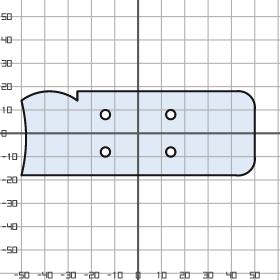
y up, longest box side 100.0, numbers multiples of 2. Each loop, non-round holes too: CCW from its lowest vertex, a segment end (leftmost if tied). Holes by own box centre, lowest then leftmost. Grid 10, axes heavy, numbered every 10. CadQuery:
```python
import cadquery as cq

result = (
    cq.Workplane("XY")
    .moveTo(-50.0, -18.0)
    .lineTo(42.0, -18.0)
    .threePointArc((48.0, -16.0), (50.0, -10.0))
    .lineTo(50.0, 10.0)
    .threePointArc((48.0, 16.0), (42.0, 18.0))
    .lineTo(-26.0, 18.0)
    .lineTo(-26.0, 14.0)
    .threePointArc((-38.0, 18.0), (-50.0, 14.0))
    .threePointArc((-48.0, -2.0), (-50.0, -18.0))
    .close()
    .moveTo(-14.0, -8.0)
    .circle(2.0)
    .moveTo(14.0, -8.0)
    .circle(2.0)
    .moveTo(-14.0, 8.0)
    .circle(2.0)
    .moveTo(14.0, 8.0)
    .circle(2.0)
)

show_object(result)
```